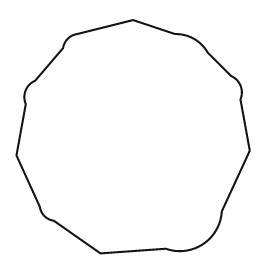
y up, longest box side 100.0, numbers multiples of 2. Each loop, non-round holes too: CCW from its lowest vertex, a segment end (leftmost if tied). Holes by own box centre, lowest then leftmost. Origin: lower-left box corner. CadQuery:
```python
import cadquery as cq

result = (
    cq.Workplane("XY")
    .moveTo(36.0, 0.0)
    .lineTo(64.0, 2.0)
    .threePointArc((80.0, 4.0), (88.0, 18.0))
    .lineTo(100.0, 44.0)
    .lineTo(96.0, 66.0)
    .threePointArc((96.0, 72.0), (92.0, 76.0))
    .lineTo(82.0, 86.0)
    .threePointArc((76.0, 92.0), (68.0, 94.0))
    .lineTo(50.0, 100.0)
    .lineTo(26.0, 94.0)
    .threePointArc((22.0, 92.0), (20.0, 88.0))
    .lineTo(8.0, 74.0)
    .threePointArc((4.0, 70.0), (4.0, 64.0))
    .lineTo(0.0, 42.0)
    .lineTo(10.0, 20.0)
    .threePointArc((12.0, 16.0), (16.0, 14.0))
    .close()
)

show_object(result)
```